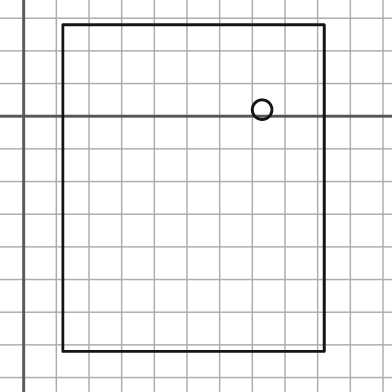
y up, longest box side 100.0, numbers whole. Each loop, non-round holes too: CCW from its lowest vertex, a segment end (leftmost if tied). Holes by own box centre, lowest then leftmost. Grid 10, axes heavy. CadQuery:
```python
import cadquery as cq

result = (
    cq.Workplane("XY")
    .moveTo(12.0, -72.0)
    .lineTo(92.0, -72.0)
    .lineTo(92.0, 28.0)
    .lineTo(12.0, 28.0)
    .close()
    .moveTo(73.0, 2.0)
    .circle(3.0)
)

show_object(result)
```